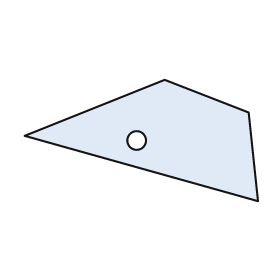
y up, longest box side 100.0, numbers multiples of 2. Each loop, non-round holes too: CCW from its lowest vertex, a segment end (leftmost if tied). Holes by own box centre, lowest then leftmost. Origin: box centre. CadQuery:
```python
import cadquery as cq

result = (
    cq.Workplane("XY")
    .moveTo(50.0, -26.0)
    .lineTo(46.0, 12.0)
    .lineTo(10.0, 26.0)
    .lineTo(-50.0, 2.0)
    .close()
    .moveTo(-2.0, 0.0)
    .circle(4.0)
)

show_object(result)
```